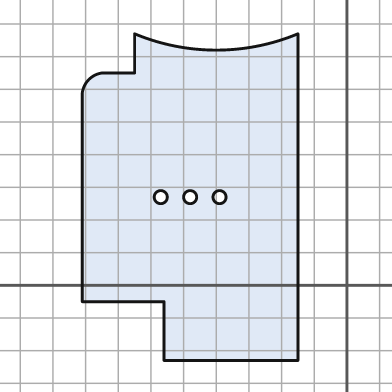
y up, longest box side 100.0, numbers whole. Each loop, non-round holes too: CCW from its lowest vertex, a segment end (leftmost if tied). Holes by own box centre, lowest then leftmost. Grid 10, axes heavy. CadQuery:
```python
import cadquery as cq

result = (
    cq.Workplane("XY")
    .moveTo(-56.0, -23.0)
    .lineTo(-15.0, -23.0)
    .lineTo(-15.0, 77.0)
    .threePointArc((-40.0, 72.0), (-65.0, 77.0))
    .lineTo(-65.0, 65.0)
    .lineTo(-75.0, 65.0)
    .threePointArc((-79.0, 63.0), (-81.0, 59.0))
    .lineTo(-81.0, -5.0)
    .lineTo(-56.0, -5.0)
    .close()
    .moveTo(-57.0, 27.0)
    .circle(2.0)
    .moveTo(-48.0, 27.0)
    .circle(2.0)
    .moveTo(-39.0, 27.0)
    .circle(2.0)
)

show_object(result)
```